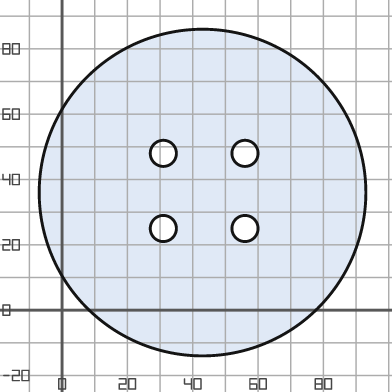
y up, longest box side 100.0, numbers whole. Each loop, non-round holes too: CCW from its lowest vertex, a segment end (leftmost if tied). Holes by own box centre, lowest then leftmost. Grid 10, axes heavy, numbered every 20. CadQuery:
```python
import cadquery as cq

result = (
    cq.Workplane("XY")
    .moveTo(43.0, 36.0)
    .circle(50.0)
    .moveTo(31.0, 25.0)
    .circle(4.0)
    .moveTo(56.0, 25.0)
    .circle(4.0)
    .moveTo(31.0, 48.0)
    .circle(4.0)
    .moveTo(56.0, 48.0)
    .circle(4.0)
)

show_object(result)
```